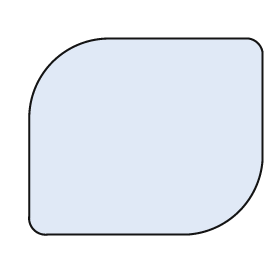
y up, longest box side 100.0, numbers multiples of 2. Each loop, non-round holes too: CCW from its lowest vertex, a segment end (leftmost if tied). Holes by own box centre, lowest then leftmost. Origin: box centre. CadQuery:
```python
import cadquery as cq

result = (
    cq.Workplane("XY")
    .moveTo(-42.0, -42.0)
    .lineTo(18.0, -42.0)
    .threePointArc((40.0, -32.0), (50.0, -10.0))
    .lineTo(50.0, 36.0)
    .threePointArc((48.0, 40.0), (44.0, 42.0))
    .lineTo(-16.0, 42.0)
    .threePointArc((-40.0, 32.0), (-50.0, 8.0))
    .lineTo(-50.0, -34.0)
    .threePointArc((-48.0, -40.0), (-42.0, -42.0))
    .close()
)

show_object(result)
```